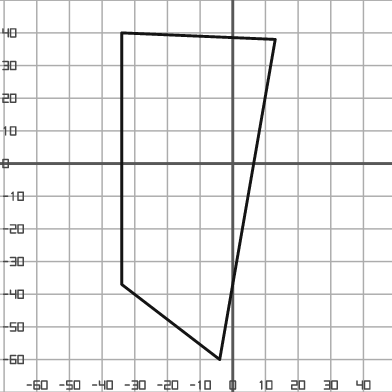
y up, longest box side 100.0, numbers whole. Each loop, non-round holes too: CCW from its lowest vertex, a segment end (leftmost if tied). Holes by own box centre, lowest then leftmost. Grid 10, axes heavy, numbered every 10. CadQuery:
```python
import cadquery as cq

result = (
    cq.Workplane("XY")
    .moveTo(-4.0, -60.0)
    .lineTo(13.0, 38.0)
    .lineTo(-34.0, 40.0)
    .lineTo(-34.0, -37.0)
    .close()
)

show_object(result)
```